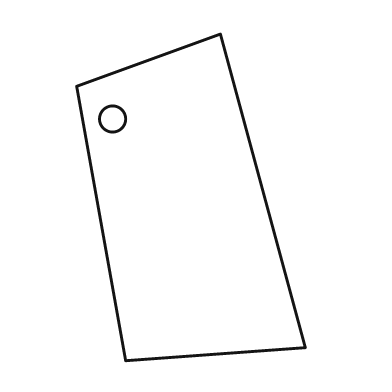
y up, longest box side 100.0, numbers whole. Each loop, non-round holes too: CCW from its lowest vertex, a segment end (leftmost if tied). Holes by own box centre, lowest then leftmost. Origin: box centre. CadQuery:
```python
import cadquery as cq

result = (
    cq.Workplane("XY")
    .moveTo(-20.0, -50.0)
    .lineTo(35.0, -46.0)
    .lineTo(9.0, 50.0)
    .lineTo(-35.0, 34.0)
    .close()
    .moveTo(-24.0, 24.0)
    .circle(4.0)
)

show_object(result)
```